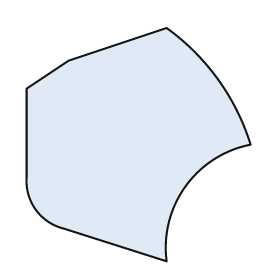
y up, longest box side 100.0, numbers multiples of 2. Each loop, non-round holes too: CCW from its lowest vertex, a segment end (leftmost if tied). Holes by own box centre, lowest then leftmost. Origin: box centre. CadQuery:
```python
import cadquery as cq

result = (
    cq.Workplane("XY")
    .moveTo(12.0, -50.0)
    .threePointArc((20.0, -18.0), (48.0, 0.0))
    .threePointArc((34.0, 28.0), (12.0, 50.0))
    .lineTo(-30.0, 36.0)
    .lineTo(-48.0, 24.0)
    .lineTo(-48.0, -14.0)
    .threePointArc((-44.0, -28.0), (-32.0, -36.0))
    .close()
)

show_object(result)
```